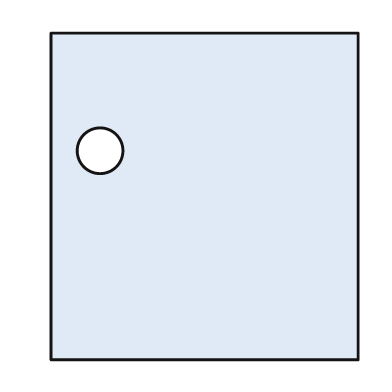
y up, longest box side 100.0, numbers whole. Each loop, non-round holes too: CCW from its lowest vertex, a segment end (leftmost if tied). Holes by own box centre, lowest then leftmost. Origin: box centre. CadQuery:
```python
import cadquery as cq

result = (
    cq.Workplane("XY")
    .moveTo(-47.0, -50.0)
    .lineTo(47.0, -50.0)
    .lineTo(47.0, 50.0)
    .lineTo(-47.0, 50.0)
    .close()
    .moveTo(-32.0, 14.0)
    .circle(7.0)
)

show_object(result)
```